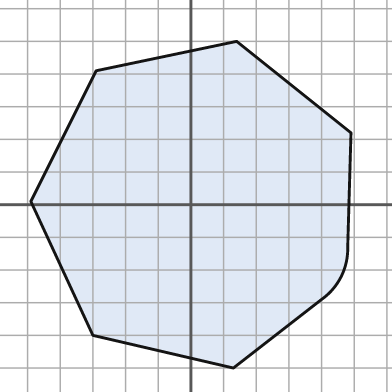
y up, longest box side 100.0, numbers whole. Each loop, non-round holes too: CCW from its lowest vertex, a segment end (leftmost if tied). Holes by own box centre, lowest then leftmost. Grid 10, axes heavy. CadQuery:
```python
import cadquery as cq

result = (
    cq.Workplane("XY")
    .moveTo(13.0, -50.0)
    .lineTo(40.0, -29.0)
    .threePointArc((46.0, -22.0), (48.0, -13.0))
    .lineTo(49.0, 22.0)
    .lineTo(14.0, 50.0)
    .lineTo(-29.0, 41.0)
    .lineTo(-49.0, 1.0)
    .lineTo(-30.0, -40.0)
    .close()
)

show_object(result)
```